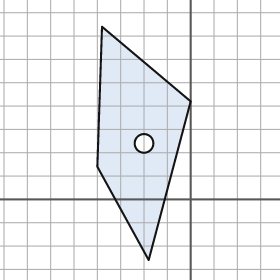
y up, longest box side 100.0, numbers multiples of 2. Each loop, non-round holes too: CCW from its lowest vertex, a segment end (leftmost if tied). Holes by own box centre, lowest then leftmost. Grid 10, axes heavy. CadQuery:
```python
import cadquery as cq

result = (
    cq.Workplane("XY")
    .moveTo(-18.0, -26.0)
    .lineTo(0.0, 42.0)
    .lineTo(-38.0, 74.0)
    .lineTo(-40.0, 14.0)
    .close()
    .moveTo(-20.0, 24.0)
    .circle(4.0)
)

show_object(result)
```